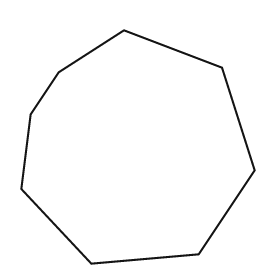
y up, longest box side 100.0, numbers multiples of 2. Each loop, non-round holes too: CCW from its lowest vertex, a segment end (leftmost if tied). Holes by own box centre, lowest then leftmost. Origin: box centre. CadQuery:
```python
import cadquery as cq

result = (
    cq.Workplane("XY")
    .moveTo(-20.0, -50.0)
    .lineTo(26.0, -46.0)
    .lineTo(50.0, -10.0)
    .lineTo(36.0, 34.0)
    .lineTo(-6.0, 50.0)
    .lineTo(-34.0, 32.0)
    .lineTo(-46.0, 14.0)
    .lineTo(-50.0, -18.0)
    .close()
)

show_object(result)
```